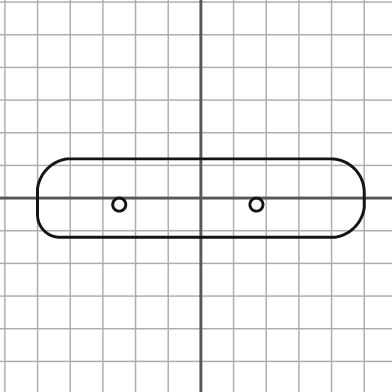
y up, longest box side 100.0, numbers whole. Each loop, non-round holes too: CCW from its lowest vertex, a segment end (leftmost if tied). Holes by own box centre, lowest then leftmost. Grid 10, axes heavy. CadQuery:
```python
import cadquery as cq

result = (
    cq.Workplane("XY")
    .moveTo(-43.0, -12.0)
    .lineTo(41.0, -12.0)
    .threePointArc((47.0, -9.0), (50.0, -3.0))
    .lineTo(50.0, 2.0)
    .threePointArc((47.0, 9.0), (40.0, 12.0))
    .lineTo(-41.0, 12.0)
    .threePointArc((-47.0, 9.0), (-50.0, 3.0))
    .lineTo(-50.0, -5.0)
    .threePointArc((-48.0, -10.0), (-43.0, -12.0))
    .close()
    .moveTo(-25.0, -2.0)
    .circle(2.0)
    .moveTo(17.0, -2.0)
    .circle(2.0)
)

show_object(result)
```